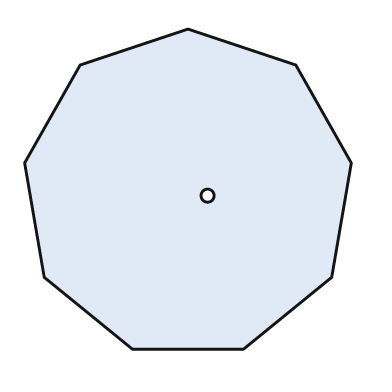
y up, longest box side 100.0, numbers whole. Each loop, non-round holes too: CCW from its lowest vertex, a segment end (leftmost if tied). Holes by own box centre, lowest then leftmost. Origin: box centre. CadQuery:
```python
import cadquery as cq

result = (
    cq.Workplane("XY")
    .moveTo(-17.0, -49.0)
    .lineTo(17.0, -49.0)
    .lineTo(44.0, -27.0)
    .lineTo(50.0, 8.0)
    .lineTo(33.0, 38.0)
    .lineTo(0.0, 49.0)
    .lineTo(-33.0, 38.0)
    .lineTo(-50.0, 8.0)
    .lineTo(-44.0, -27.0)
    .close()
    .moveTo(6.0, -2.0)
    .circle(2.0)
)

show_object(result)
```